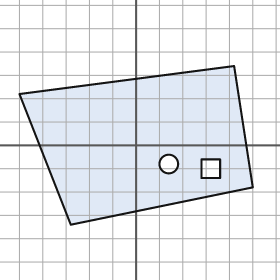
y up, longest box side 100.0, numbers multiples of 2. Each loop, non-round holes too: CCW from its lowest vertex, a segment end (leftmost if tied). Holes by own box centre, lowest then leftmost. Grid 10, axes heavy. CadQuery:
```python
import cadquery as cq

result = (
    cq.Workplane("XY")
    .moveTo(-28.0, -34.0)
    .lineTo(50.0, -18.0)
    .lineTo(42.0, 34.0)
    .lineTo(-50.0, 22.0)
    .close()
    .moveTo(28.0, -14.0)
    .lineTo(36.0, -14.0)
    .lineTo(36.0, -6.0)
    .lineTo(28.0, -6.0)
    .close()
    .moveTo(14.0, -8.0)
    .circle(4.0)
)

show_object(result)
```